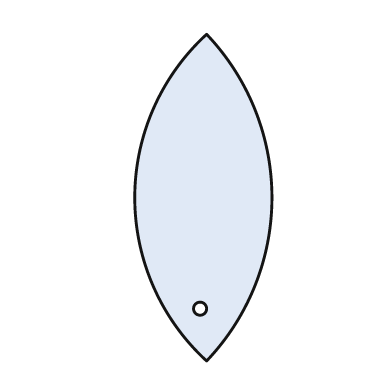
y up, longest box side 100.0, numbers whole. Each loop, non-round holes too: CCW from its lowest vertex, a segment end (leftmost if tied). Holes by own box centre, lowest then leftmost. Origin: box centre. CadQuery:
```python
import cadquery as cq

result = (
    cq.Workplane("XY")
    .moveTo(1.0, -50.0)
    .threePointArc((21.0, 0.0), (1.0, 50.0))
    .threePointArc((-21.0, 0.0), (1.0, -50.0))
    .close()
    .moveTo(-1.0, -34.0)
    .circle(2.0)
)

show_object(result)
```